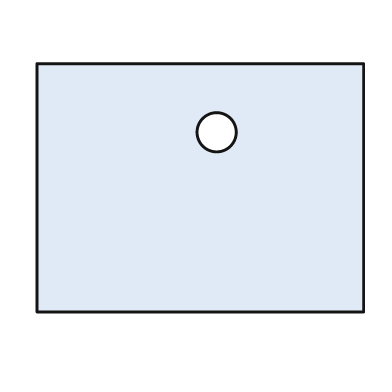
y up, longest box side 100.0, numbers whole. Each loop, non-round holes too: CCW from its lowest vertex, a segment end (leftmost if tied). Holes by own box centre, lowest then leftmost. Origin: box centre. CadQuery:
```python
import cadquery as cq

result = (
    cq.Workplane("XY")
    .moveTo(-50.0, -38.0)
    .lineTo(50.0, -38.0)
    .lineTo(50.0, 38.0)
    .lineTo(-50.0, 38.0)
    .close()
    .moveTo(5.0, 17.0)
    .circle(6.0)
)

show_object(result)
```